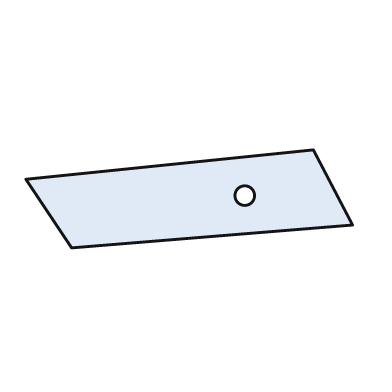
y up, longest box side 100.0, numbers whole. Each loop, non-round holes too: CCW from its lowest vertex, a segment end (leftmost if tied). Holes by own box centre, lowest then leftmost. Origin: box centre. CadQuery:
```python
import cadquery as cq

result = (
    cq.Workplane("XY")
    .moveTo(-36.0, -15.0)
    .lineTo(50.0, -8.0)
    .lineTo(38.0, 15.0)
    .lineTo(-50.0, 6.0)
    .close()
    .moveTo(17.0, 1.0)
    .circle(3.0)
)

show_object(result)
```